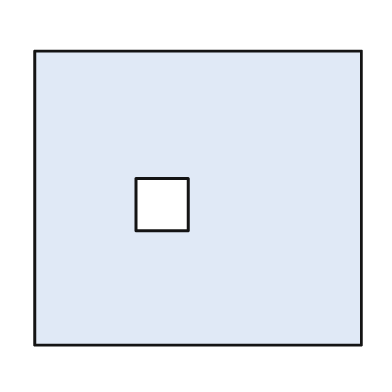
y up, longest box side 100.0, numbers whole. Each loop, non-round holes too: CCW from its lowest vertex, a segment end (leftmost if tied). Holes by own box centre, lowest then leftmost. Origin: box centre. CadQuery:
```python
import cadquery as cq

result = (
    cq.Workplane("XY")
    .moveTo(-50.0, -45.0)
    .lineTo(50.0, -45.0)
    .lineTo(50.0, 45.0)
    .lineTo(-50.0, 45.0)
    .close()
    .moveTo(-19.0, -10.0)
    .lineTo(-3.0, -10.0)
    .lineTo(-3.0, 6.0)
    .lineTo(-19.0, 6.0)
    .close()
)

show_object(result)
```